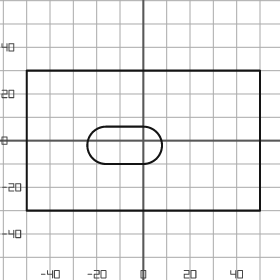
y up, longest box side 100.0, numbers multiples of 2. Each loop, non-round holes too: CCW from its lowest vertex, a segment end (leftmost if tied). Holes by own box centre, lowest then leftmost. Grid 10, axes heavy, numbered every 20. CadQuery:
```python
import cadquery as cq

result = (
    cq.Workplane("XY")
    .moveTo(-50.0, -30.0)
    .lineTo(50.0, -30.0)
    .lineTo(50.0, 30.0)
    .lineTo(-50.0, 30.0)
    .close()
    .moveTo(-16.0, -10.0)
    .lineTo(0.0, -10.0)
    .threePointArc((8.0, -2.0), (0.0, 6.0))
    .lineTo(-16.0, 6.0)
    .threePointArc((-24.0, -2.0), (-16.0, -10.0))
    .close()
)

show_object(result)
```